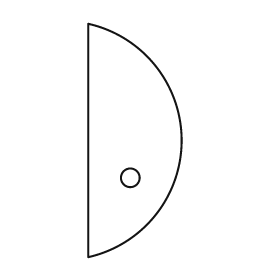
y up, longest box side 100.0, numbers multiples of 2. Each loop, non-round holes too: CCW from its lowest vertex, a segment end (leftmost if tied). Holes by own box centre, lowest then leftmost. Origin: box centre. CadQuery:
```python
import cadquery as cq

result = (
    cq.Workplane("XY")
    .moveTo(-20.0, -50.0)
    .threePointArc((20.0, 0.0), (-20.0, 50.0))
    .close()
    .moveTo(-2.0, -16.0)
    .circle(4.0)
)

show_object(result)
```